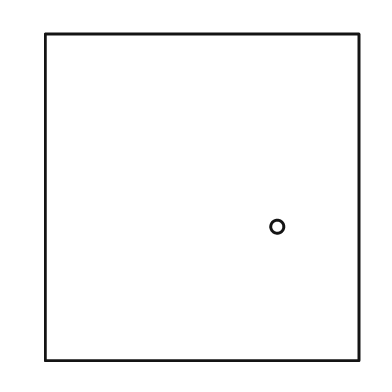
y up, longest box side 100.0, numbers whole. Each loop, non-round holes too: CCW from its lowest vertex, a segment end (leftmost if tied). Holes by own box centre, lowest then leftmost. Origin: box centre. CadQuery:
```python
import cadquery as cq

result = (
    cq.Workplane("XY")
    .moveTo(-48.0, -50.0)
    .lineTo(48.0, -50.0)
    .lineTo(48.0, 50.0)
    .lineTo(-48.0, 50.0)
    .close()
    .moveTo(23.0, -9.0)
    .circle(2.0)
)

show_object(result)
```